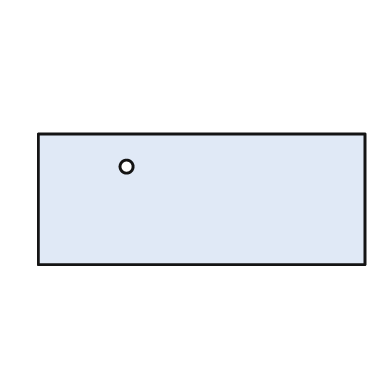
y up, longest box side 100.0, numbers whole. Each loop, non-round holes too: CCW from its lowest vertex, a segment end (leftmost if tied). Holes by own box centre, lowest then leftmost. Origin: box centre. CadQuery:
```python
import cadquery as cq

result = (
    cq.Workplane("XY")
    .moveTo(-50.0, -20.0)
    .lineTo(50.0, -20.0)
    .lineTo(50.0, 20.0)
    .lineTo(-50.0, 20.0)
    .close()
    .moveTo(-23.0, 10.0)
    .circle(2.0)
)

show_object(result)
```